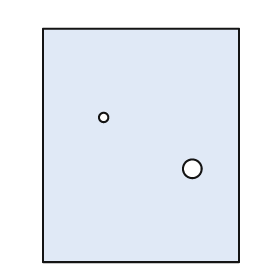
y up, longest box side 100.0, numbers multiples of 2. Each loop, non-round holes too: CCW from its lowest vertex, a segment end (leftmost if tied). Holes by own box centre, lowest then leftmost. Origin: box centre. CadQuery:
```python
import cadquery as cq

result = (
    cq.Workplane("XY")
    .moveTo(-42.0, -50.0)
    .lineTo(42.0, -50.0)
    .lineTo(42.0, 50.0)
    .lineTo(-42.0, 50.0)
    .close()
    .moveTo(22.0, -10.0)
    .circle(4.0)
    .moveTo(-16.0, 12.0)
    .circle(2.0)
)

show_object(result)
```